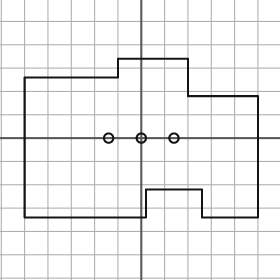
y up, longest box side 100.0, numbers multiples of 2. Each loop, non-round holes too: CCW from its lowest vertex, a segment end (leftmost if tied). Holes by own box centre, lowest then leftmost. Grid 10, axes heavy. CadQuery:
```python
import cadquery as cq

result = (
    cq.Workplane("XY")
    .moveTo(-50.0, -34.0)
    .lineTo(2.0, -34.0)
    .lineTo(2.0, -22.0)
    .lineTo(26.0, -22.0)
    .lineTo(26.0, -34.0)
    .lineTo(50.0, -34.0)
    .lineTo(50.0, 18.0)
    .lineTo(20.0, 18.0)
    .lineTo(20.0, 34.0)
    .lineTo(-10.0, 34.0)
    .lineTo(-10.0, 26.0)
    .lineTo(-50.0, 26.0)
    .close()
    .moveTo(-14.0, 0.0)
    .circle(2.0)
    .moveTo(0.0, 0.0)
    .circle(2.0)
    .moveTo(14.0, 0.0)
    .circle(2.0)
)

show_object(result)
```